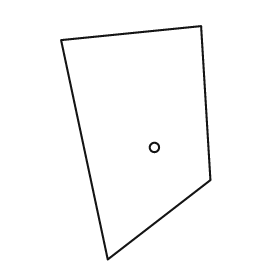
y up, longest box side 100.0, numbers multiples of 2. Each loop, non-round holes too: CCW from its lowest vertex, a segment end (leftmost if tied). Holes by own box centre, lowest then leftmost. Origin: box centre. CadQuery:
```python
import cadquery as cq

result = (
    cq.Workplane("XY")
    .moveTo(-12.0, -50.0)
    .lineTo(32.0, -16.0)
    .lineTo(28.0, 50.0)
    .lineTo(-32.0, 44.0)
    .close()
    .moveTo(8.0, -2.0)
    .circle(2.0)
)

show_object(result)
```